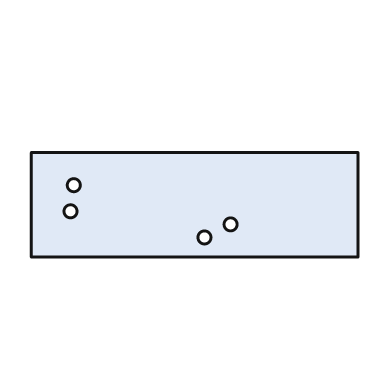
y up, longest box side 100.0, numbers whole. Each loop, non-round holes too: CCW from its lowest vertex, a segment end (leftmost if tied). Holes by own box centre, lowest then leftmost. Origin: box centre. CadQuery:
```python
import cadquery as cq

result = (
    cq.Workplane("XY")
    .moveTo(-50.0, -16.0)
    .lineTo(50.0, -16.0)
    .lineTo(50.0, 16.0)
    .lineTo(-50.0, 16.0)
    .close()
    .moveTo(3.0, -10.0)
    .circle(2.0)
    .moveTo(11.0, -6.0)
    .circle(2.0)
    .moveTo(-38.0, -2.0)
    .circle(2.0)
    .moveTo(-37.0, 6.0)
    .circle(2.0)
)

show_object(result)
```